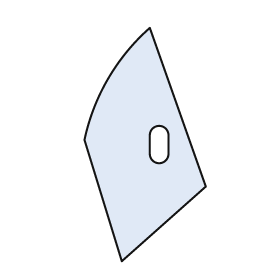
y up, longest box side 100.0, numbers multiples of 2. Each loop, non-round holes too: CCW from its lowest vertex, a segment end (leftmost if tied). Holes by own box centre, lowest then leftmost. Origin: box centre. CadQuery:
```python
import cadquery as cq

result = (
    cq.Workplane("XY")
    .moveTo(-10.0, -50.0)
    .lineTo(26.0, -18.0)
    .lineTo(2.0, 50.0)
    .threePointArc((-16.0, 28.0), (-26.0, 2.0))
    .close()
    .moveTo(2.0, -4.0)
    .threePointArc((6.0, -8.0), (10.0, -4.0))
    .lineTo(10.0, 4.0)
    .threePointArc((6.0, 8.0), (2.0, 4.0))
    .close()
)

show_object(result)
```